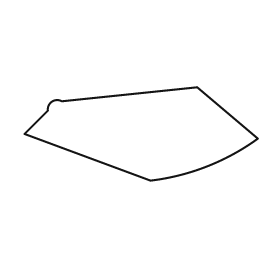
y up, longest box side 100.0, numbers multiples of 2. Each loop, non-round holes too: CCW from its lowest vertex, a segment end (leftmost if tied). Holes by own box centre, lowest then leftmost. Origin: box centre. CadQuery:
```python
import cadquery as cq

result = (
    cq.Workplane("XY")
    .moveTo(4.0, -20.0)
    .threePointArc((28.0, -14.0), (50.0, -2.0))
    .lineTo(24.0, 20.0)
    .lineTo(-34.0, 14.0)
    .threePointArc((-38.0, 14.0), (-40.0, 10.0))
    .lineTo(-50.0, 0.0)
    .close()
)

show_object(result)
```